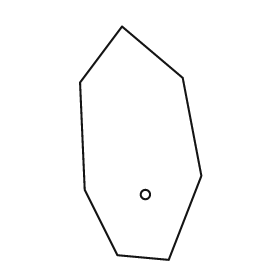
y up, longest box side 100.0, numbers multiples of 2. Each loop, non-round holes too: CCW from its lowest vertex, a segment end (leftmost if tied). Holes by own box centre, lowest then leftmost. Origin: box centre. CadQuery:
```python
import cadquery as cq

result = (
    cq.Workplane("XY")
    .moveTo(12.0, -50.0)
    .lineTo(26.0, -14.0)
    .lineTo(18.0, 28.0)
    .lineTo(-8.0, 50.0)
    .lineTo(-26.0, 26.0)
    .lineTo(-24.0, -20.0)
    .lineTo(-10.0, -48.0)
    .close()
    .moveTo(2.0, -22.0)
    .circle(2.0)
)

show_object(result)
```